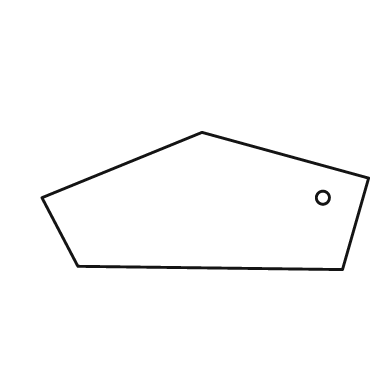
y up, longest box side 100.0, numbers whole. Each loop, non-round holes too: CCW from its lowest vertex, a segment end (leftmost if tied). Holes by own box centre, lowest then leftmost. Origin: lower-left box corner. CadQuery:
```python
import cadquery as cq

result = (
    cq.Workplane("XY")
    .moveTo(92.0, 0.0)
    .lineTo(100.0, 28.0)
    .lineTo(49.0, 42.0)
    .lineTo(0.0, 22.0)
    .lineTo(11.0, 1.0)
    .close()
    .moveTo(86.0, 22.0)
    .circle(2.0)
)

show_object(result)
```